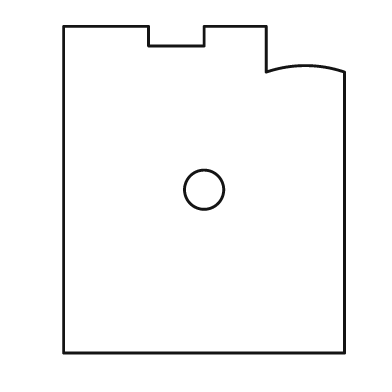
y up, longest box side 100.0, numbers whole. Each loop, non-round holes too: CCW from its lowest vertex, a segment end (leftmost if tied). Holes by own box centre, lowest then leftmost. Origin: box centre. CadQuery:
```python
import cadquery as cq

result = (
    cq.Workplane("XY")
    .moveTo(-43.0, -50.0)
    .lineTo(43.0, -50.0)
    .lineTo(43.0, 36.0)
    .threePointArc((31.0, 38.0), (19.0, 36.0))
    .lineTo(19.0, 50.0)
    .lineTo(0.0, 50.0)
    .lineTo(0.0, 44.0)
    .lineTo(-17.0, 44.0)
    .lineTo(-17.0, 50.0)
    .lineTo(-43.0, 50.0)
    .close()
    .moveTo(0.0, 0.0)
    .circle(6.0)
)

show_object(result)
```